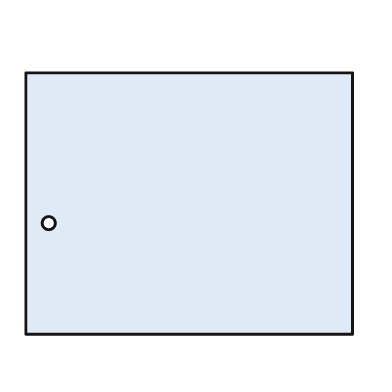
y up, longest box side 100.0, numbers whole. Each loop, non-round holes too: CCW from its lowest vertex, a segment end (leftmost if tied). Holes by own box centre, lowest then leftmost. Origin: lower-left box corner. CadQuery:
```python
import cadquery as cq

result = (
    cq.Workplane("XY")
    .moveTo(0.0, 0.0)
    .lineTo(100.0, 0.0)
    .lineTo(100.0, 80.0)
    .lineTo(0.0, 80.0)
    .close()
    .moveTo(7.0, 34.0)
    .circle(2.0)
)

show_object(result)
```